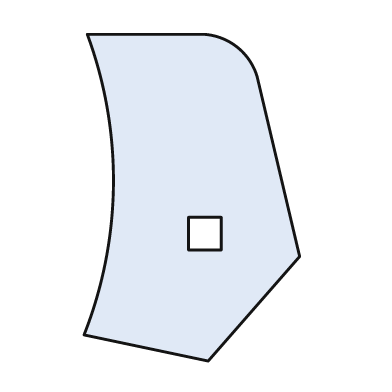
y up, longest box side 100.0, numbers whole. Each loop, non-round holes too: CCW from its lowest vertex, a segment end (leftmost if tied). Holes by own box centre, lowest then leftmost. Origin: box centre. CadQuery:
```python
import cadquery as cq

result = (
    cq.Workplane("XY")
    .moveTo(5.0, -50.0)
    .lineTo(33.0, -18.0)
    .lineTo(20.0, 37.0)
    .threePointArc((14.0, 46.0), (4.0, 50.0))
    .lineTo(-32.0, 50.0)
    .threePointArc((-24.0, 4.0), (-33.0, -42.0))
    .close()
    .moveTo(-1.0, -16.0)
    .lineTo(9.0, -16.0)
    .lineTo(9.0, -6.0)
    .lineTo(-1.0, -6.0)
    .close()
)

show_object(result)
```